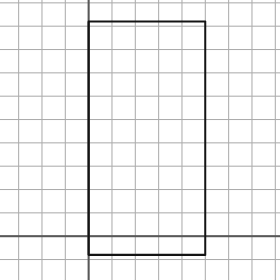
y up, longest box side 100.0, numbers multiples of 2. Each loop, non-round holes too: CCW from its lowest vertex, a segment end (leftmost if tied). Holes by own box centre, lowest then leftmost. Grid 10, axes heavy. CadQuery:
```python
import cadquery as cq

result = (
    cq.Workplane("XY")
    .moveTo(0.0, -8.0)
    .lineTo(50.0, -8.0)
    .lineTo(50.0, 92.0)
    .lineTo(0.0, 92.0)
    .close()
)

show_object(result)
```